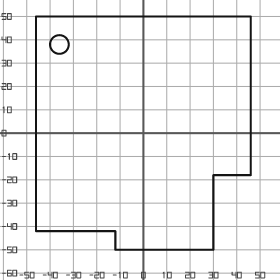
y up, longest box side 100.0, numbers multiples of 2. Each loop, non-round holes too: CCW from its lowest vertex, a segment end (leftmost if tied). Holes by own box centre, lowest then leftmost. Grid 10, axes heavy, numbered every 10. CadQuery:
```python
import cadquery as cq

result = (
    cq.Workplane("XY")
    .moveTo(-12.0, -50.0)
    .lineTo(30.0, -50.0)
    .lineTo(30.0, -18.0)
    .lineTo(46.0, -18.0)
    .lineTo(46.0, 50.0)
    .lineTo(-46.0, 50.0)
    .lineTo(-46.0, -42.0)
    .lineTo(-12.0, -42.0)
    .close()
    .moveTo(-36.0, 38.0)
    .circle(4.0)
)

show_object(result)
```